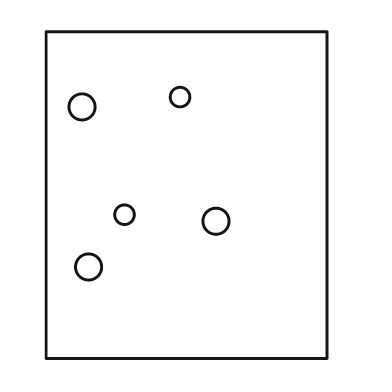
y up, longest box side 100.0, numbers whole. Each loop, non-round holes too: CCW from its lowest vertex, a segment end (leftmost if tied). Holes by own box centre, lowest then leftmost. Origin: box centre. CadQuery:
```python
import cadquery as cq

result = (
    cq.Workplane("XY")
    .moveTo(-43.0, -50.0)
    .lineTo(43.0, -50.0)
    .lineTo(43.0, 50.0)
    .lineTo(-43.0, 50.0)
    .close()
    .moveTo(-30.0, -22.0)
    .circle(4.0)
    .moveTo(9.0, -8.0)
    .circle(4.0)
    .moveTo(-19.0, -6.0)
    .circle(3.0)
    .moveTo(-32.0, 27.0)
    .circle(4.0)
    .moveTo(-2.0, 30.0)
    .circle(3.0)
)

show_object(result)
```